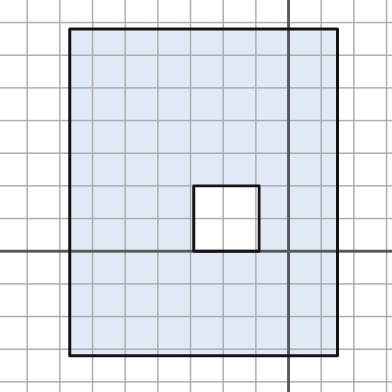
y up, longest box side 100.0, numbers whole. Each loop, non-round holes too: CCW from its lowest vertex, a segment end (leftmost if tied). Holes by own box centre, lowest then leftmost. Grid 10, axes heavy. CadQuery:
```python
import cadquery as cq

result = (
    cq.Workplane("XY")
    .moveTo(-67.0, -32.0)
    .lineTo(15.0, -32.0)
    .lineTo(15.0, 68.0)
    .lineTo(-67.0, 68.0)
    .close()
    .moveTo(-29.0, 0.0)
    .lineTo(-9.0, 0.0)
    .lineTo(-9.0, 20.0)
    .lineTo(-29.0, 20.0)
    .close()
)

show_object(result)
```